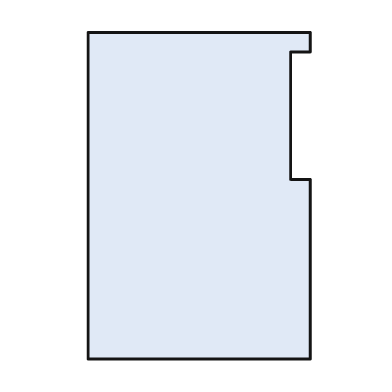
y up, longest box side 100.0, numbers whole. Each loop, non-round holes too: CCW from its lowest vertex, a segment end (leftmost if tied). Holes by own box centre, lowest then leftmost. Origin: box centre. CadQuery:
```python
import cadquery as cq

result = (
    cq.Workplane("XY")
    .moveTo(-34.0, -50.0)
    .lineTo(34.0, -50.0)
    .lineTo(34.0, 5.0)
    .lineTo(28.0, 5.0)
    .lineTo(28.0, 44.0)
    .lineTo(34.0, 44.0)
    .lineTo(34.0, 50.0)
    .lineTo(-34.0, 50.0)
    .close()
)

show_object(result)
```